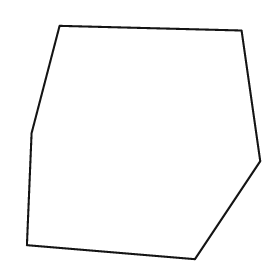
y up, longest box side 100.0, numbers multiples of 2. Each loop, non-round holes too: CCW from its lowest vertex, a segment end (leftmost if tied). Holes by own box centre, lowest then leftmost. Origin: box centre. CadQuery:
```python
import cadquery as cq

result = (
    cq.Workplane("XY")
    .moveTo(22.0, -50.0)
    .lineTo(50.0, -8.0)
    .lineTo(42.0, 48.0)
    .lineTo(-36.0, 50.0)
    .lineTo(-48.0, 4.0)
    .lineTo(-50.0, -44.0)
    .close()
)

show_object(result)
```